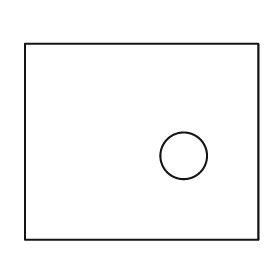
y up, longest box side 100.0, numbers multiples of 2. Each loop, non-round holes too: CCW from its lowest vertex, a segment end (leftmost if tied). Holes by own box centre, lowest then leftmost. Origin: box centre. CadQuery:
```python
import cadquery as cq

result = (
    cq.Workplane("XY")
    .moveTo(-50.0, -42.0)
    .lineTo(50.0, -42.0)
    .lineTo(50.0, 42.0)
    .lineTo(-50.0, 42.0)
    .close()
    .moveTo(18.0, -6.0)
    .circle(10.0)
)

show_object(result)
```